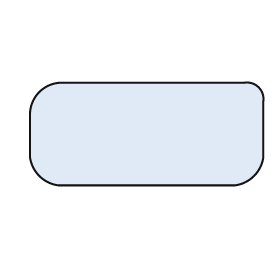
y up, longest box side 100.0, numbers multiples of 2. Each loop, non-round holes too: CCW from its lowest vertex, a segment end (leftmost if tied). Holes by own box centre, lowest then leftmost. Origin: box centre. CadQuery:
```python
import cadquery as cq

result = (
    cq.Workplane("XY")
    .moveTo(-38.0, -22.0)
    .lineTo(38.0, -22.0)
    .threePointArc((46.0, -18.0), (50.0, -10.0))
    .lineTo(50.0, 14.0)
    .threePointArc((48.0, 20.0), (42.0, 22.0))
    .lineTo(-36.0, 22.0)
    .threePointArc((-46.0, 18.0), (-50.0, 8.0))
    .lineTo(-50.0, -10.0)
    .threePointArc((-46.0, -18.0), (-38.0, -22.0))
    .close()
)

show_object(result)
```